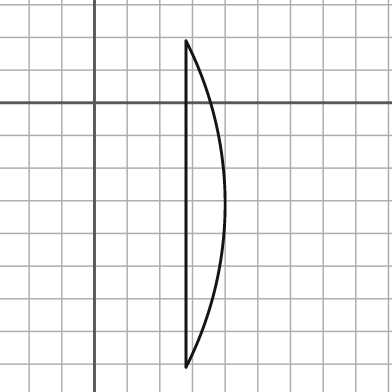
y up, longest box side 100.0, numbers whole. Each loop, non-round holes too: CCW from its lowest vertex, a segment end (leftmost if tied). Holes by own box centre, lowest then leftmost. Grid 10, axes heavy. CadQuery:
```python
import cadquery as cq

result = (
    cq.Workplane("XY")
    .moveTo(28.0, -81.0)
    .threePointArc((40.0, -31.0), (28.0, 19.0))
    .close()
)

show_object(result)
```